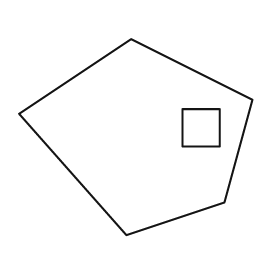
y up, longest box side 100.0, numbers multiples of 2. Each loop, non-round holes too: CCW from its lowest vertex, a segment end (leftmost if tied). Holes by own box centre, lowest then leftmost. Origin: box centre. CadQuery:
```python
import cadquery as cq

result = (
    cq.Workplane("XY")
    .moveTo(-4.0, -42.0)
    .lineTo(38.0, -28.0)
    .lineTo(50.0, 16.0)
    .lineTo(-2.0, 42.0)
    .lineTo(-50.0, 10.0)
    .close()
    .moveTo(20.0, -4.0)
    .lineTo(36.0, -4.0)
    .lineTo(36.0, 12.0)
    .lineTo(20.0, 12.0)
    .close()
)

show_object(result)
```